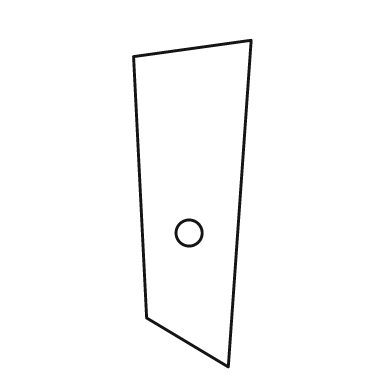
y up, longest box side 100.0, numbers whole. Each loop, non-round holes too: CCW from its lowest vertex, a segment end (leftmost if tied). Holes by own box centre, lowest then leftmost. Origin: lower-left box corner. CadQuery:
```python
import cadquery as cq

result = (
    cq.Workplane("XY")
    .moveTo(29.0, 0.0)
    .lineTo(36.0, 100.0)
    .lineTo(0.0, 95.0)
    .lineTo(4.0, 15.0)
    .close()
    .moveTo(17.0, 41.0)
    .circle(4.0)
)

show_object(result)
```